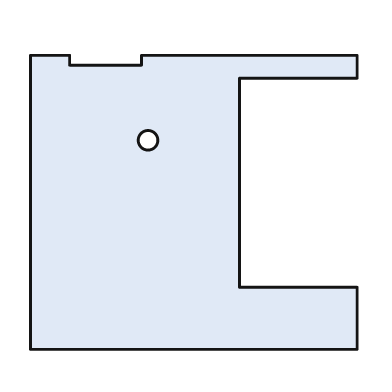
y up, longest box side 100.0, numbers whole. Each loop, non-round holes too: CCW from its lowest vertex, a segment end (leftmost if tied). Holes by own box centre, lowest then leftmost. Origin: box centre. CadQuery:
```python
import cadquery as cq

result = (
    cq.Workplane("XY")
    .moveTo(-50.0, -45.0)
    .lineTo(50.0, -45.0)
    .lineTo(50.0, -26.0)
    .lineTo(14.0, -26.0)
    .lineTo(14.0, 38.0)
    .lineTo(50.0, 38.0)
    .lineTo(50.0, 45.0)
    .lineTo(-16.0, 45.0)
    .lineTo(-16.0, 42.0)
    .lineTo(-38.0, 42.0)
    .lineTo(-38.0, 45.0)
    .lineTo(-50.0, 45.0)
    .close()
    .moveTo(-14.0, 19.0)
    .circle(3.0)
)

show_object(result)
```